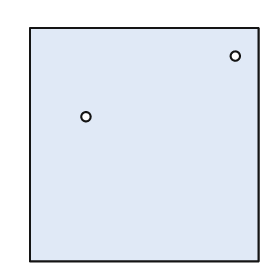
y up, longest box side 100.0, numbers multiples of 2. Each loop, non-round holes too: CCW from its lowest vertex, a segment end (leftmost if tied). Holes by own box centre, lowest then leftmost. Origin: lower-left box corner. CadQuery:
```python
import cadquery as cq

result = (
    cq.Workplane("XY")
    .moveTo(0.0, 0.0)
    .lineTo(98.0, 0.0)
    .lineTo(98.0, 100.0)
    .lineTo(0.0, 100.0)
    .close()
    .moveTo(24.0, 62.0)
    .circle(2.0)
    .moveTo(88.0, 88.0)
    .circle(2.0)
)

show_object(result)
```